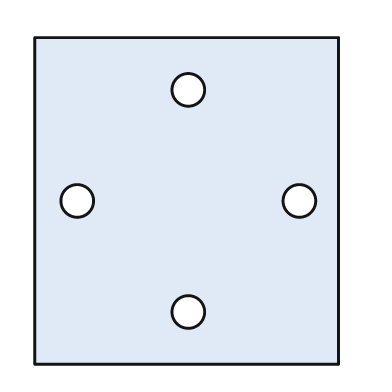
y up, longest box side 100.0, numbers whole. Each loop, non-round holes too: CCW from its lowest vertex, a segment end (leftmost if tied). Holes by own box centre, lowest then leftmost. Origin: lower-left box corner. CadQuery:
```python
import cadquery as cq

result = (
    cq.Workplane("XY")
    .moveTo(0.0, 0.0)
    .lineTo(93.0, 0.0)
    .lineTo(93.0, 100.0)
    .lineTo(0.0, 100.0)
    .close()
    .moveTo(47.0, 16.0)
    .circle(5.0)
    .moveTo(13.0, 50.0)
    .circle(5.0)
    .moveTo(81.0, 50.0)
    .circle(5.0)
    .moveTo(47.0, 84.0)
    .circle(5.0)
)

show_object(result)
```